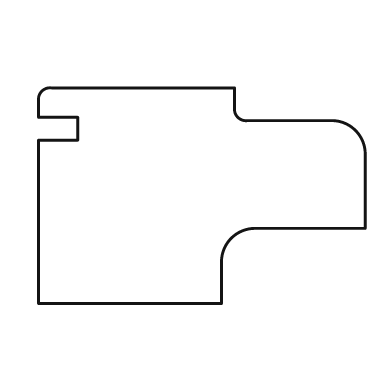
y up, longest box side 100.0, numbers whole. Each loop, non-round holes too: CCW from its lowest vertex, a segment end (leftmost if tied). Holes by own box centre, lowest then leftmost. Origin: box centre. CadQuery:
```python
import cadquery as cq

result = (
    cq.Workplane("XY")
    .moveTo(-50.0, -33.0)
    .lineTo(6.0, -33.0)
    .lineTo(6.0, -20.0)
    .threePointArc((9.0, -13.0), (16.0, -10.0))
    .lineTo(50.0, -10.0)
    .lineTo(50.0, 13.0)
    .threePointArc((47.0, 20.0), (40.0, 23.0))
    .lineTo(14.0, 23.0)
    .threePointArc((11.0, 24.0), (10.0, 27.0))
    .lineTo(10.0, 33.0)
    .lineTo(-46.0, 33.0)
    .threePointArc((-49.0, 32.0), (-50.0, 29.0))
    .lineTo(-50.0, 24.0)
    .lineTo(-38.0, 24.0)
    .lineTo(-38.0, 17.0)
    .lineTo(-50.0, 17.0)
    .close()
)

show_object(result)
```